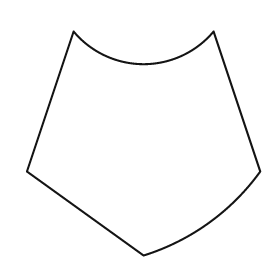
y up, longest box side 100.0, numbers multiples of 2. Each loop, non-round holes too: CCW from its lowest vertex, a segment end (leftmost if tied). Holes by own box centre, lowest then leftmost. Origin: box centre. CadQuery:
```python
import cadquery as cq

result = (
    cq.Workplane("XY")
    .moveTo(0.0, -48.0)
    .threePointArc((28.0, -34.0), (50.0, -12.0))
    .lineTo(30.0, 48.0)
    .threePointArc((0.0, 34.0), (-30.0, 48.0))
    .lineTo(-50.0, -12.0)
    .close()
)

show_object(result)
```